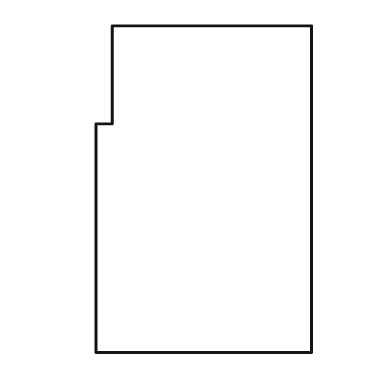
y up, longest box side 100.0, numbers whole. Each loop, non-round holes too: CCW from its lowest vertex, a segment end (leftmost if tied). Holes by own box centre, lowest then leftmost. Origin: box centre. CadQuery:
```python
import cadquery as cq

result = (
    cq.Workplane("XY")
    .moveTo(-33.0, -50.0)
    .lineTo(33.0, -50.0)
    .lineTo(33.0, 50.0)
    .lineTo(-28.0, 50.0)
    .lineTo(-28.0, 20.0)
    .lineTo(-33.0, 20.0)
    .close()
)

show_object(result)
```